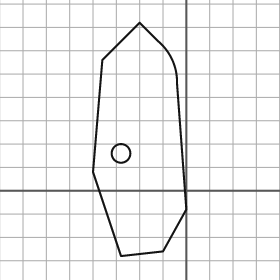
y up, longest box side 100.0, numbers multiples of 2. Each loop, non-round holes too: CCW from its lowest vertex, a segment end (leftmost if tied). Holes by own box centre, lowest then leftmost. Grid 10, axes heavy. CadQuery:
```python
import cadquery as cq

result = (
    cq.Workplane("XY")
    .moveTo(-28.0, -28.0)
    .lineTo(-10.0, -26.0)
    .lineTo(0.0, -8.0)
    .lineTo(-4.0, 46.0)
    .threePointArc((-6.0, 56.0), (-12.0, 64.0))
    .lineTo(-20.0, 72.0)
    .lineTo(-36.0, 56.0)
    .lineTo(-40.0, 8.0)
    .close()
    .moveTo(-28.0, 16.0)
    .circle(4.0)
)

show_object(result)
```